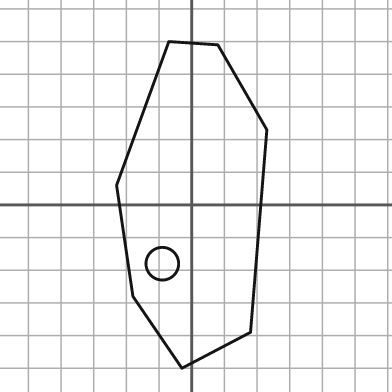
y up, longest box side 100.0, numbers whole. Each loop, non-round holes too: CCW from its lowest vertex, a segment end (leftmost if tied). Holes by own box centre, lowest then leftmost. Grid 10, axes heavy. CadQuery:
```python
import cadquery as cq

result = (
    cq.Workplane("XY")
    .moveTo(-3.0, -50.0)
    .lineTo(18.0, -39.0)
    .lineTo(23.0, 23.0)
    .lineTo(8.0, 49.0)
    .lineTo(-7.0, 50.0)
    .lineTo(-23.0, 6.0)
    .lineTo(-18.0, -28.0)
    .close()
    .moveTo(-9.0, -18.0)
    .circle(5.0)
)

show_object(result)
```